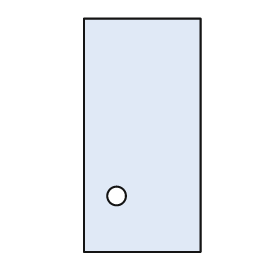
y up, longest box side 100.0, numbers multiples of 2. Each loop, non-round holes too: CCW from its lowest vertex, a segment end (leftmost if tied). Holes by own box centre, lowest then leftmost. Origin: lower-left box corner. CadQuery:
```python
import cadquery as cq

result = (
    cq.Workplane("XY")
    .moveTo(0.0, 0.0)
    .lineTo(50.0, 0.0)
    .lineTo(50.0, 100.0)
    .lineTo(0.0, 100.0)
    .close()
    .moveTo(14.0, 24.0)
    .circle(4.0)
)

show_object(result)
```